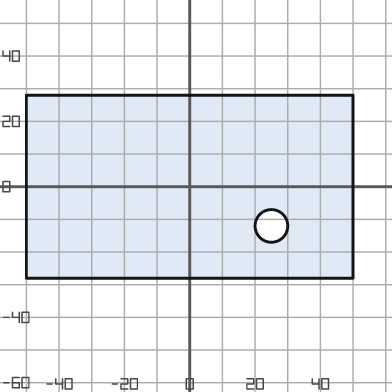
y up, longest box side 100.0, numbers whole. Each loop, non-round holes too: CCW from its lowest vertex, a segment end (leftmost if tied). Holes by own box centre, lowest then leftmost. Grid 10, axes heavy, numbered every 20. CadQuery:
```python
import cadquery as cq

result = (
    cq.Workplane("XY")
    .moveTo(-50.0, -28.0)
    .lineTo(50.0, -28.0)
    .lineTo(50.0, 28.0)
    .lineTo(-50.0, 28.0)
    .close()
    .moveTo(25.0, -12.0)
    .circle(5.0)
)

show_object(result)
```